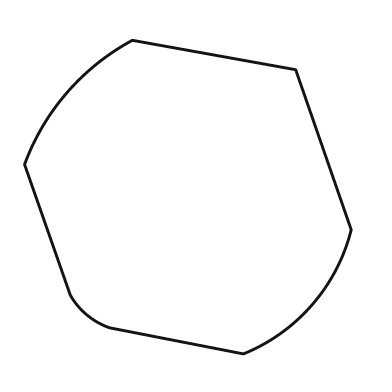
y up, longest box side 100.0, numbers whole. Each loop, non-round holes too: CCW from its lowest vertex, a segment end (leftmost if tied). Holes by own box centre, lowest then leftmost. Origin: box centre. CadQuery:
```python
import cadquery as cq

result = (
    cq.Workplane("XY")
    .moveTo(17.0, -48.0)
    .threePointArc((38.0, -33.0), (50.0, -10.0))
    .lineTo(33.0, 39.0)
    .lineTo(-17.0, 48.0)
    .threePointArc((-37.0, 32.0), (-50.0, 10.0))
    .lineTo(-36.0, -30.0)
    .threePointArc((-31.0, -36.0), (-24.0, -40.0))
    .close()
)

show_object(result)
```